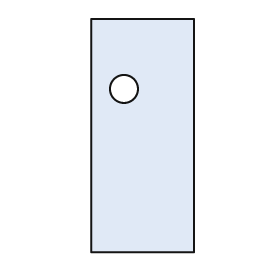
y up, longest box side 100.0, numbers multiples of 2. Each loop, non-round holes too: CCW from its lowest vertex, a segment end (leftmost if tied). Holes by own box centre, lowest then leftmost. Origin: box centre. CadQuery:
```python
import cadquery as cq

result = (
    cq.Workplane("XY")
    .moveTo(-22.0, -50.0)
    .lineTo(22.0, -50.0)
    .lineTo(22.0, 50.0)
    .lineTo(-22.0, 50.0)
    .close()
    .moveTo(-8.0, 20.0)
    .circle(6.0)
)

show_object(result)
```